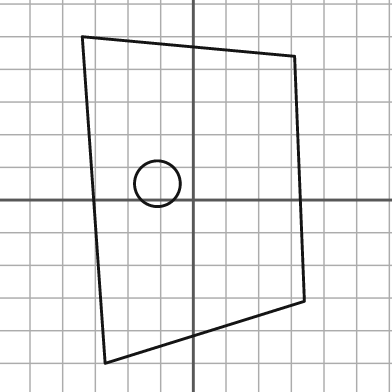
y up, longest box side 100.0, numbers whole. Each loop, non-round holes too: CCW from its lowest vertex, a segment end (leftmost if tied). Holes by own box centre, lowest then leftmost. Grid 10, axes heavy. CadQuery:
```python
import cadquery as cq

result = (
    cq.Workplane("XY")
    .moveTo(-27.0, -50.0)
    .lineTo(34.0, -31.0)
    .lineTo(31.0, 44.0)
    .lineTo(-34.0, 50.0)
    .close()
    .moveTo(-11.0, 5.0)
    .circle(7.0)
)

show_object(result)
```